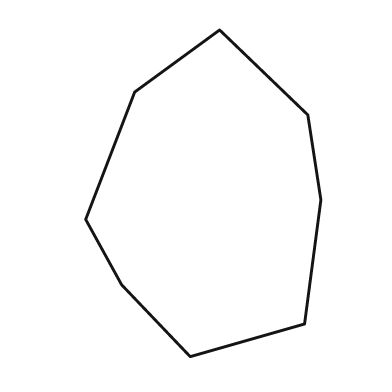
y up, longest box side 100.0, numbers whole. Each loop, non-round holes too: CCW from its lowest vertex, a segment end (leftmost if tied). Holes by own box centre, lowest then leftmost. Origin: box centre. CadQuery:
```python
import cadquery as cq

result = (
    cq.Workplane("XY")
    .moveTo(-4.0, -50.0)
    .lineTo(31.0, -40.0)
    .lineTo(36.0, -2.0)
    .lineTo(32.0, 24.0)
    .lineTo(5.0, 50.0)
    .lineTo(-21.0, 31.0)
    .lineTo(-36.0, -8.0)
    .lineTo(-25.0, -28.0)
    .close()
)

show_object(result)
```